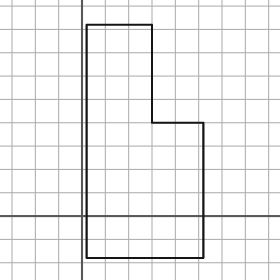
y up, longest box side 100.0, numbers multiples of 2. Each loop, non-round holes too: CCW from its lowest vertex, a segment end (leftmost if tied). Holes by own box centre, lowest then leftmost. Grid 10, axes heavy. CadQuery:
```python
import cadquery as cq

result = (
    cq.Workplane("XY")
    .moveTo(2.0, -18.0)
    .lineTo(52.0, -18.0)
    .lineTo(52.0, 40.0)
    .lineTo(30.0, 40.0)
    .lineTo(30.0, 82.0)
    .lineTo(2.0, 82.0)
    .close()
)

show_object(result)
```